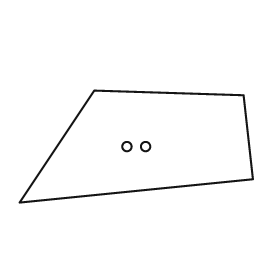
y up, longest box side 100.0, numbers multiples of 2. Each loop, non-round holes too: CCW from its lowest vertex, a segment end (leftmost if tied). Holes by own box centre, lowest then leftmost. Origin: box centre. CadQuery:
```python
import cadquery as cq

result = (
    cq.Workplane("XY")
    .moveTo(-50.0, -24.0)
    .lineTo(50.0, -14.0)
    .lineTo(46.0, 22.0)
    .lineTo(-18.0, 24.0)
    .close()
    .moveTo(-4.0, 0.0)
    .circle(2.0)
    .moveTo(4.0, 0.0)
    .circle(2.0)
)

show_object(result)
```